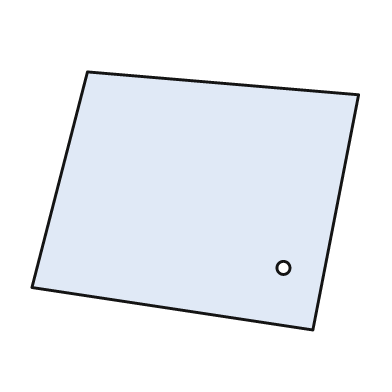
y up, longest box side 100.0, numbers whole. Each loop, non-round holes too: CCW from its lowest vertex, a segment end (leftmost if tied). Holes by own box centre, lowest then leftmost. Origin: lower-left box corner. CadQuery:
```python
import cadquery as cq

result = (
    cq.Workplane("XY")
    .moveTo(86.0, 0.0)
    .lineTo(100.0, 72.0)
    .lineTo(17.0, 79.0)
    .lineTo(0.0, 13.0)
    .close()
    .moveTo(77.0, 19.0)
    .circle(2.0)
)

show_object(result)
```